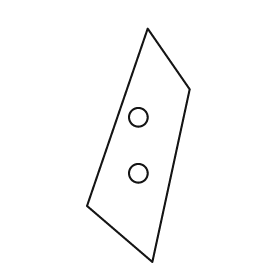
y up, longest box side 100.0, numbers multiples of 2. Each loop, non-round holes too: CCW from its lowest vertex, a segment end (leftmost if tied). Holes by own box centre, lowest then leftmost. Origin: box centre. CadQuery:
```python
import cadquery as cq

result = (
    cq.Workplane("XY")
    .moveTo(6.0, -50.0)
    .lineTo(22.0, 24.0)
    .lineTo(4.0, 50.0)
    .lineTo(-22.0, -26.0)
    .close()
    .moveTo(0.0, -12.0)
    .circle(4.0)
    .moveTo(0.0, 12.0)
    .circle(4.0)
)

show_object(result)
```